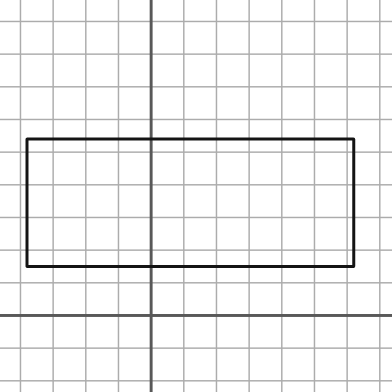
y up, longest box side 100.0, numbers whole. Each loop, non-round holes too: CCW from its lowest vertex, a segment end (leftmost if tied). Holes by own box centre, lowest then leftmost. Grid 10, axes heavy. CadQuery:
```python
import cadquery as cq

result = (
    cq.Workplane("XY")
    .moveTo(-38.0, 15.0)
    .lineTo(62.0, 15.0)
    .lineTo(62.0, 54.0)
    .lineTo(-38.0, 54.0)
    .close()
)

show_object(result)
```